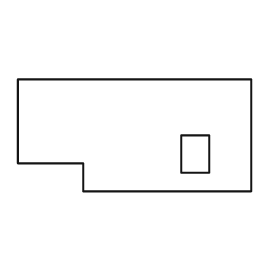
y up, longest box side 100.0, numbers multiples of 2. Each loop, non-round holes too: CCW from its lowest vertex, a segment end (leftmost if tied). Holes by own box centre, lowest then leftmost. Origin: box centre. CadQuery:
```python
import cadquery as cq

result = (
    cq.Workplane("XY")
    .moveTo(-22.0, -24.0)
    .lineTo(50.0, -24.0)
    .lineTo(50.0, 24.0)
    .lineTo(-50.0, 24.0)
    .lineTo(-50.0, -12.0)
    .lineTo(-22.0, -12.0)
    .close()
    .moveTo(20.0, -16.0)
    .lineTo(32.0, -16.0)
    .lineTo(32.0, 0.0)
    .lineTo(20.0, 0.0)
    .close()
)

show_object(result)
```